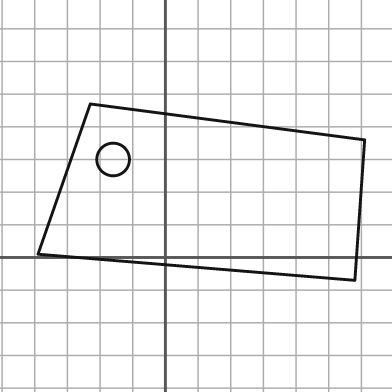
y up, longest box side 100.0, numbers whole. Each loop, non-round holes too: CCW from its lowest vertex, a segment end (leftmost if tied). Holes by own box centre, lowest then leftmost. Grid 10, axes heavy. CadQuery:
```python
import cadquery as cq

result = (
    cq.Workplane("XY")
    .moveTo(58.0, -7.0)
    .lineTo(61.0, 36.0)
    .lineTo(-23.0, 47.0)
    .lineTo(-39.0, 1.0)
    .close()
    .moveTo(-16.0, 30.0)
    .circle(5.0)
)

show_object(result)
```